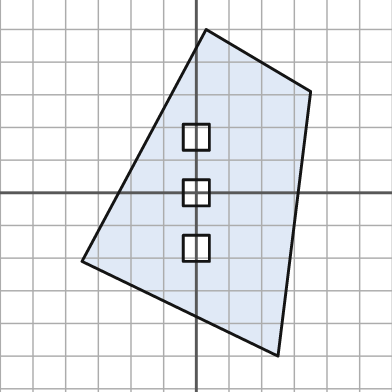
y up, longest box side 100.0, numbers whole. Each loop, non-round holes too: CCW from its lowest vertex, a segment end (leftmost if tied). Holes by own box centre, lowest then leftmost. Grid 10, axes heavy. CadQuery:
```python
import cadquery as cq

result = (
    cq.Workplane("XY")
    .moveTo(25.0, -50.0)
    .lineTo(35.0, 31.0)
    .lineTo(3.0, 50.0)
    .lineTo(-35.0, -21.0)
    .close()
    .moveTo(-4.0, -21.0)
    .lineTo(4.0, -21.0)
    .lineTo(4.0, -13.0)
    .lineTo(-4.0, -13.0)
    .close()
    .moveTo(-4.0, -4.0)
    .lineTo(4.0, -4.0)
    .lineTo(4.0, 4.0)
    .lineTo(-4.0, 4.0)
    .close()
    .moveTo(-4.0, 13.0)
    .lineTo(4.0, 13.0)
    .lineTo(4.0, 21.0)
    .lineTo(-4.0, 21.0)
    .close()
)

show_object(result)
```